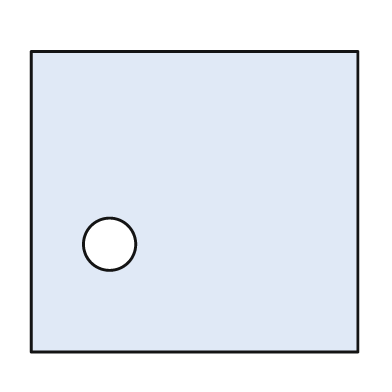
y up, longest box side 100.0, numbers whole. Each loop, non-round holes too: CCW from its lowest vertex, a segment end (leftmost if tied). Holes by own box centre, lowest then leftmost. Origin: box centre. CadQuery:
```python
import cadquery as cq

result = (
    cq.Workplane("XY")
    .moveTo(-50.0, -46.0)
    .lineTo(50.0, -46.0)
    .lineTo(50.0, 46.0)
    .lineTo(-50.0, 46.0)
    .close()
    .moveTo(-26.0, -13.0)
    .circle(8.0)
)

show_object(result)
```